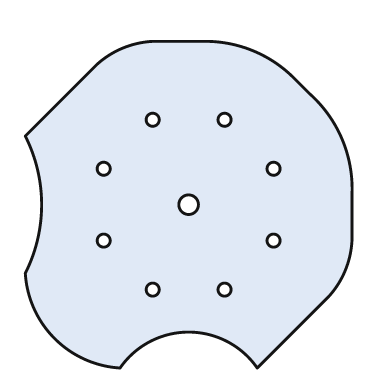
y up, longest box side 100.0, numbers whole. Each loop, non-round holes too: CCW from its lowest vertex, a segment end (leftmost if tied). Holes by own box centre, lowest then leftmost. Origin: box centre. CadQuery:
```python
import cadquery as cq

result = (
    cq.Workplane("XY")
    .moveTo(-21.0, -50.0)
    .threePointArc((0.0, -39.0), (21.0, -50.0))
    .lineTo(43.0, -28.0)
    .threePointArc((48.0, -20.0), (50.0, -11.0))
    .lineTo(50.0, 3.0)
    .threePointArc((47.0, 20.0), (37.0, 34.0))
    .lineTo(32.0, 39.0)
    .threePointArc((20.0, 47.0), (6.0, 50.0))
    .lineTo(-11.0, 50.0)
    .threePointArc((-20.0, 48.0), (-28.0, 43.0))
    .lineTo(-50.0, 21.0)
    .threePointArc((-45.0, 0.0), (-50.0, -21.0))
    .threePointArc((-41.0, -41.0), (-21.0, -50.0))
    .close()
    .moveTo(-11.0, -26.0)
    .circle(2.0)
    .moveTo(11.0, -26.0)
    .circle(2.0)
    .moveTo(-26.0, -11.0)
    .circle(2.0)
    .moveTo(26.0, -11.0)
    .circle(2.0)
    .moveTo(0.0, 0.0)
    .circle(3.0)
    .moveTo(-26.0, 11.0)
    .circle(2.0)
    .moveTo(26.0, 11.0)
    .circle(2.0)
    .moveTo(-11.0, 26.0)
    .circle(2.0)
    .moveTo(11.0, 26.0)
    .circle(2.0)
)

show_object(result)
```